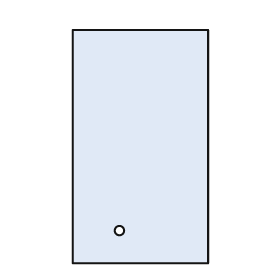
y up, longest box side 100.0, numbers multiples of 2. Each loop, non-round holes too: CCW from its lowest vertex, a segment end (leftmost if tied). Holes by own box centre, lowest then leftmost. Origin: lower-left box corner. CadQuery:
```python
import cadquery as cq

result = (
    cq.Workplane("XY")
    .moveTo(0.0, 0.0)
    .lineTo(58.0, 0.0)
    .lineTo(58.0, 100.0)
    .lineTo(0.0, 100.0)
    .close()
    .moveTo(20.0, 14.0)
    .circle(2.0)
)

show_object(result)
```